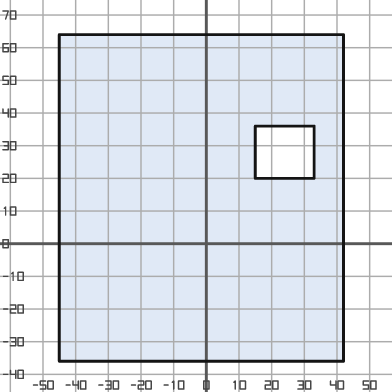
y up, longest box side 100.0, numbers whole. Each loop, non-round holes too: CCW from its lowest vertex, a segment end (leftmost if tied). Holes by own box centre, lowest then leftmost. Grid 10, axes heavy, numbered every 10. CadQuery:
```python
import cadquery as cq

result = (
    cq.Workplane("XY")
    .moveTo(-45.0, -36.0)
    .lineTo(42.0, -36.0)
    .lineTo(42.0, 64.0)
    .lineTo(-45.0, 64.0)
    .close()
    .moveTo(15.0, 20.0)
    .lineTo(33.0, 20.0)
    .lineTo(33.0, 36.0)
    .lineTo(15.0, 36.0)
    .close()
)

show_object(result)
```